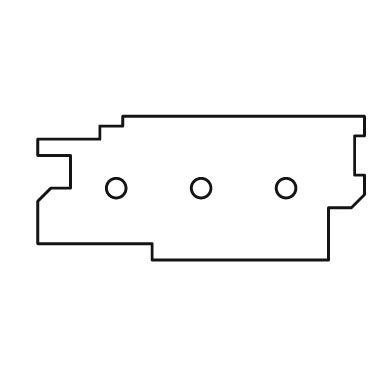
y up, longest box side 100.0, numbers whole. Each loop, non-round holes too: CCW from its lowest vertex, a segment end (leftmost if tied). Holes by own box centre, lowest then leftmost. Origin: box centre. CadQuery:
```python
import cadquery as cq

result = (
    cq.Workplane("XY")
    .moveTo(-15.0, -22.0)
    .lineTo(39.0, -22.0)
    .lineTo(39.0, -6.0)
    .lineTo(46.0, -6.0)
    .lineTo(50.0, -2.0)
    .lineTo(50.0, 4.0)
    .lineTo(47.0, 4.0)
    .lineTo(47.0, 16.0)
    .lineTo(50.0, 16.0)
    .lineTo(50.0, 22.0)
    .lineTo(-24.0, 22.0)
    .lineTo(-24.0, 19.0)
    .lineTo(-31.0, 19.0)
    .lineTo(-31.0, 15.0)
    .lineTo(-50.0, 15.0)
    .lineTo(-50.0, 10.0)
    .lineTo(-40.0, 10.0)
    .lineTo(-40.0, 0.0)
    .lineTo(-46.0, 0.0)
    .lineTo(-50.0, -4.0)
    .lineTo(-50.0, -17.0)
    .lineTo(-15.0, -17.0)
    .close()
    .moveTo(-26.0, 0.0)
    .circle(3.0)
    .moveTo(0.0, 0.0)
    .circle(3.0)
    .moveTo(26.0, 0.0)
    .circle(3.0)
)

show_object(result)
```